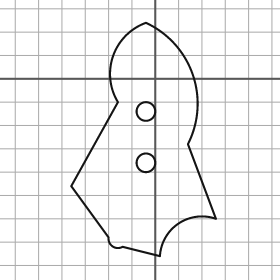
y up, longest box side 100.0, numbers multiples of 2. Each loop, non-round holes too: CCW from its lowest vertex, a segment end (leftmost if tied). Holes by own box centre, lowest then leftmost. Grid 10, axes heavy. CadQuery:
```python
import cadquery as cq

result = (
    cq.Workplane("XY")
    .moveTo(2.0, -76.0)
    .threePointArc((10.0, -62.0), (26.0, -60.0))
    .lineTo(14.0, -28.0)
    .threePointArc((16.0, 2.0), (-4.0, 24.0))
    .threePointArc((-18.0, 10.0), (-16.0, -10.0))
    .lineTo(-36.0, -46.0)
    .lineTo(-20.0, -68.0)
    .threePointArc((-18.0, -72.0), (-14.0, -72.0))
    .close()
    .moveTo(-4.0, -36.0)
    .circle(4.0)
    .moveTo(-4.0, -14.0)
    .circle(4.0)
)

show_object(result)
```